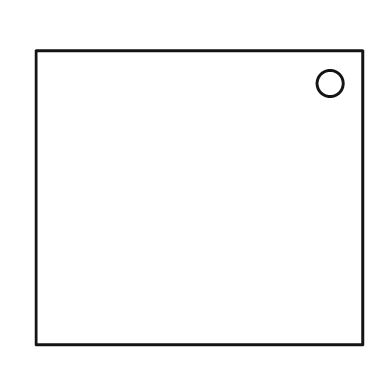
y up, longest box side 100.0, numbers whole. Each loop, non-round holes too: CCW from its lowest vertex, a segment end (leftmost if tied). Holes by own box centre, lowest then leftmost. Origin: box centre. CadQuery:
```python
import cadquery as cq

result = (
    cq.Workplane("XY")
    .moveTo(-50.0, -45.0)
    .lineTo(50.0, -45.0)
    .lineTo(50.0, 45.0)
    .lineTo(-50.0, 45.0)
    .close()
    .moveTo(40.0, 35.0)
    .circle(4.0)
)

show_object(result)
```